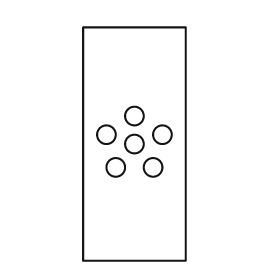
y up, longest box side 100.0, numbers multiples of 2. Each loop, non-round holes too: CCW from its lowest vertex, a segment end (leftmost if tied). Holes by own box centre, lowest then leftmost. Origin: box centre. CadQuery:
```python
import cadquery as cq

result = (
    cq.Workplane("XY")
    .moveTo(-22.0, -50.0)
    .lineTo(22.0, -50.0)
    .lineTo(22.0, 50.0)
    .lineTo(-22.0, 50.0)
    .close()
    .moveTo(-8.0, -10.0)
    .circle(4.0)
    .moveTo(8.0, -10.0)
    .circle(4.0)
    .moveTo(0.0, 0.0)
    .circle(4.0)
    .moveTo(-12.0, 4.0)
    .circle(4.0)
    .moveTo(12.0, 4.0)
    .circle(4.0)
    .moveTo(0.0, 12.0)
    .circle(4.0)
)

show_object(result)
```